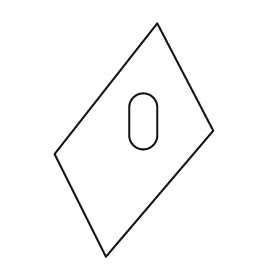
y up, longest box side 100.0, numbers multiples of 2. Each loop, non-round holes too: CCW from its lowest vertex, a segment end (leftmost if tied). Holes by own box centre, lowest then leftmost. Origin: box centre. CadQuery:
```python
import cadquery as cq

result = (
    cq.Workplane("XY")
    .moveTo(-12.0, -50.0)
    .lineTo(34.0, 4.0)
    .lineTo(10.0, 50.0)
    .lineTo(-34.0, -6.0)
    .close()
    .moveTo(-2.0, 2.0)
    .threePointArc((4.0, -4.0), (10.0, 2.0))
    .lineTo(10.0, 14.0)
    .threePointArc((4.0, 20.0), (-2.0, 14.0))
    .close()
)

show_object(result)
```